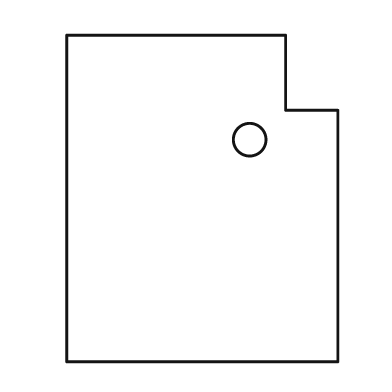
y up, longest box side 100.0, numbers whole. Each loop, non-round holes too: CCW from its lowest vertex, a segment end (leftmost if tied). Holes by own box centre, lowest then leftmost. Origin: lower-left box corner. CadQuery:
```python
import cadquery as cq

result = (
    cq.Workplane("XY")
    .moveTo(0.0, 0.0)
    .lineTo(83.0, 0.0)
    .lineTo(83.0, 77.0)
    .lineTo(67.0, 77.0)
    .lineTo(67.0, 100.0)
    .lineTo(0.0, 100.0)
    .close()
    .moveTo(56.0, 68.0)
    .circle(5.0)
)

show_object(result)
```